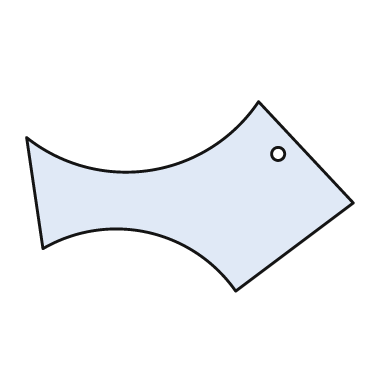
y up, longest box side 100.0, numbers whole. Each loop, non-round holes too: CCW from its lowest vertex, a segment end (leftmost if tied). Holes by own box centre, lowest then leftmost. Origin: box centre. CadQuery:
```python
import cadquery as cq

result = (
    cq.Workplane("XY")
    .moveTo(14.0, -29.0)
    .lineTo(50.0, -2.0)
    .lineTo(21.0, 29.0)
    .threePointArc((-12.0, 8.0), (-50.0, 18.0))
    .lineTo(-45.0, -16.0)
    .threePointArc((-13.0, -11.0), (14.0, -29.0))
    .close()
    .moveTo(27.0, 13.0)
    .circle(2.0)
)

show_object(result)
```